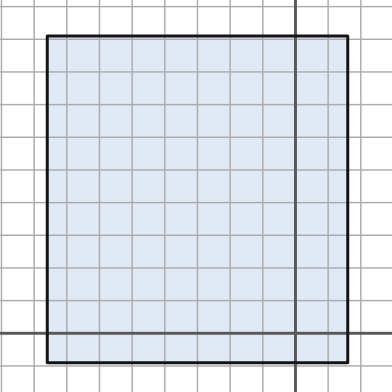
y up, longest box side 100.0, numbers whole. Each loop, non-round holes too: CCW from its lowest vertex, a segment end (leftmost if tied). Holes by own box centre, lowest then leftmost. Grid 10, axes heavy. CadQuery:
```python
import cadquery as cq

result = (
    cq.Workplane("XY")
    .moveTo(-76.0, -9.0)
    .lineTo(16.0, -9.0)
    .lineTo(16.0, 91.0)
    .lineTo(-76.0, 91.0)
    .close()
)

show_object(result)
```